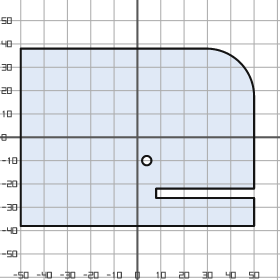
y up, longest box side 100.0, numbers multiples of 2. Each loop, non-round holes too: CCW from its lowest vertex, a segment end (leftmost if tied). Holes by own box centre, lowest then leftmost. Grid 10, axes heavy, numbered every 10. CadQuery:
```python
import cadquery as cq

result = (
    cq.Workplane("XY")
    .moveTo(-50.0, -38.0)
    .lineTo(50.0, -38.0)
    .lineTo(50.0, -26.0)
    .lineTo(8.0, -26.0)
    .lineTo(8.0, -22.0)
    .lineTo(50.0, -22.0)
    .lineTo(50.0, 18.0)
    .threePointArc((44.0, 32.0), (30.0, 38.0))
    .lineTo(-50.0, 38.0)
    .close()
    .moveTo(4.0, -10.0)
    .circle(2.0)
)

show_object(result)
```